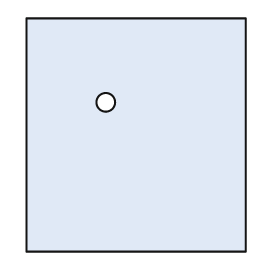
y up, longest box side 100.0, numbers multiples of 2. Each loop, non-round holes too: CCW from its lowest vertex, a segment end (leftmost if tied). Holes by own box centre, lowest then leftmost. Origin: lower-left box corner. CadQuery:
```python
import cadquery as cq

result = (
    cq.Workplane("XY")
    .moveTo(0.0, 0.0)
    .lineTo(94.0, 0.0)
    .lineTo(94.0, 100.0)
    .lineTo(0.0, 100.0)
    .close()
    .moveTo(34.0, 64.0)
    .circle(4.0)
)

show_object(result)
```